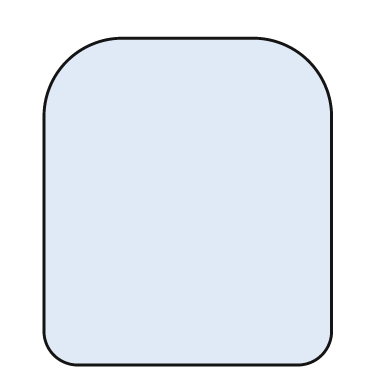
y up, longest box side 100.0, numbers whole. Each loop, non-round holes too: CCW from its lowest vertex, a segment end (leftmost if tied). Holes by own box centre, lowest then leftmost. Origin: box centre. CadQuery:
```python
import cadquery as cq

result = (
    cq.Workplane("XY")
    .moveTo(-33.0, -50.0)
    .lineTo(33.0, -50.0)
    .threePointArc((41.0, -47.0), (44.0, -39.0))
    .lineTo(44.0, 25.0)
    .threePointArc((37.0, 43.0), (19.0, 50.0))
    .lineTo(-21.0, 50.0)
    .threePointArc((-37.0, 43.0), (-44.0, 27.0))
    .lineTo(-44.0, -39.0)
    .threePointArc((-41.0, -47.0), (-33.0, -50.0))
    .close()
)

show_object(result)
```